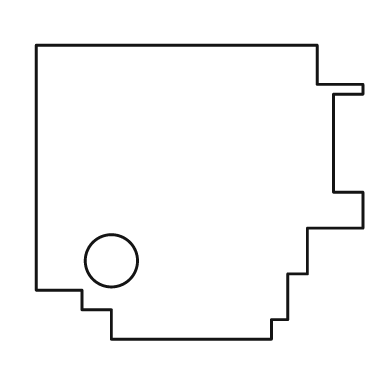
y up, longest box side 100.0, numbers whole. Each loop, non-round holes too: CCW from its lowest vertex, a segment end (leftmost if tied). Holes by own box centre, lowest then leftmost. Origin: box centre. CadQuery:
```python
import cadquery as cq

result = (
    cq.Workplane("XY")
    .moveTo(-27.0, -45.0)
    .lineTo(22.0, -45.0)
    .lineTo(22.0, -39.0)
    .lineTo(27.0, -39.0)
    .lineTo(27.0, -25.0)
    .lineTo(33.0, -25.0)
    .lineTo(33.0, -11.0)
    .lineTo(50.0, -11.0)
    .lineTo(50.0, 0.0)
    .lineTo(41.0, 0.0)
    .lineTo(41.0, 30.0)
    .lineTo(50.0, 30.0)
    .lineTo(50.0, 33.0)
    .lineTo(36.0, 33.0)
    .lineTo(36.0, 45.0)
    .lineTo(-50.0, 45.0)
    .lineTo(-50.0, -30.0)
    .lineTo(-36.0, -30.0)
    .lineTo(-36.0, -36.0)
    .lineTo(-27.0, -36.0)
    .close()
    .moveTo(-27.0, -21.0)
    .circle(8.0)
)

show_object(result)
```